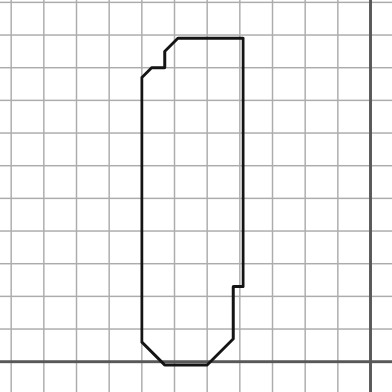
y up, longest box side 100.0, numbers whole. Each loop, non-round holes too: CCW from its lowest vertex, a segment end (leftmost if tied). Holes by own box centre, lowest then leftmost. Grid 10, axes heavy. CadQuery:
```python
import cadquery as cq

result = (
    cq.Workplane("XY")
    .moveTo(-63.0, -1.0)
    .lineTo(-50.0, -1.0)
    .lineTo(-42.0, 7.0)
    .lineTo(-42.0, 23.0)
    .lineTo(-39.0, 23.0)
    .lineTo(-39.0, 99.0)
    .lineTo(-59.0, 99.0)
    .lineTo(-63.0, 95.0)
    .lineTo(-63.0, 90.0)
    .lineTo(-67.0, 90.0)
    .lineTo(-70.0, 87.0)
    .lineTo(-70.0, 6.0)
    .close()
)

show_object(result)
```